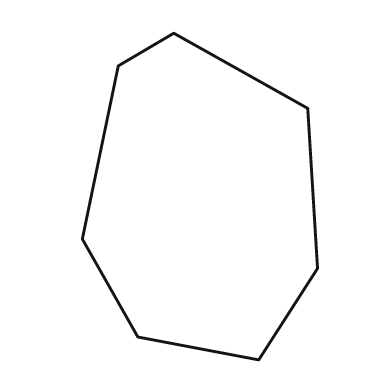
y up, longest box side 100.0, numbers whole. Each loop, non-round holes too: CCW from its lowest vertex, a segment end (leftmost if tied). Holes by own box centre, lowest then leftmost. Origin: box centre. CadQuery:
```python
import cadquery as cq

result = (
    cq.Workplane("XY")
    .moveTo(18.0, -50.0)
    .lineTo(36.0, -22.0)
    .lineTo(33.0, 27.0)
    .lineTo(-8.0, 50.0)
    .lineTo(-25.0, 40.0)
    .lineTo(-36.0, -13.0)
    .lineTo(-19.0, -43.0)
    .close()
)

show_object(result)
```